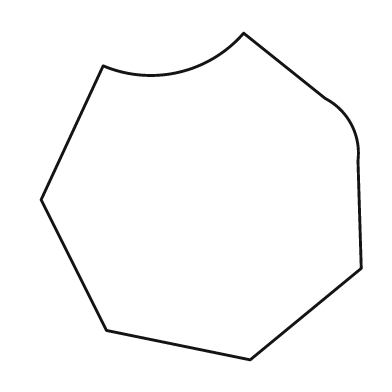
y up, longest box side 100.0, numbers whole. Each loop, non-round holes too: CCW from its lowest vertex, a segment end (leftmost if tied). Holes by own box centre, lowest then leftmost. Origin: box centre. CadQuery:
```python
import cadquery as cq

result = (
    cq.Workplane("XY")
    .moveTo(15.0, -50.0)
    .lineTo(49.0, -22.0)
    .lineTo(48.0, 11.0)
    .threePointArc((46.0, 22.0), (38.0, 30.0))
    .lineTo(13.0, 50.0)
    .threePointArc((-7.0, 38.0), (-30.0, 40.0))
    .lineTo(-49.0, -1.0)
    .lineTo(-29.0, -41.0)
    .close()
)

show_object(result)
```